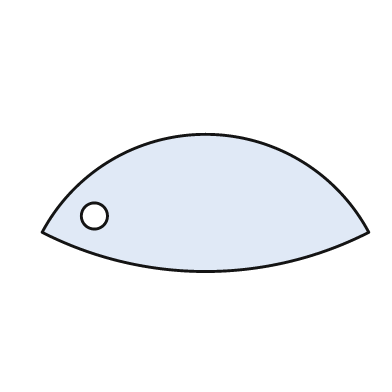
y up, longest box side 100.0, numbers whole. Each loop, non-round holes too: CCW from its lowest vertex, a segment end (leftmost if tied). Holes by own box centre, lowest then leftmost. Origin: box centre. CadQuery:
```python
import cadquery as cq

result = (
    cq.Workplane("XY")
    .moveTo(-50.0, -9.0)
    .threePointArc((0.0, -21.0), (50.0, -9.0))
    .threePointArc((0.0, 21.0), (-50.0, -9.0))
    .close()
    .moveTo(-34.0, -4.0)
    .circle(4.0)
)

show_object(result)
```